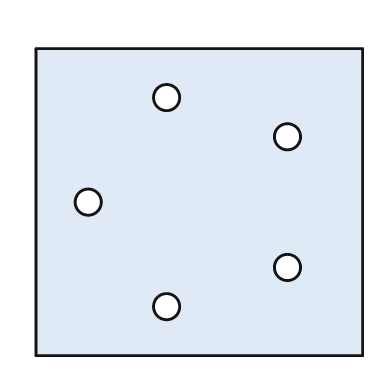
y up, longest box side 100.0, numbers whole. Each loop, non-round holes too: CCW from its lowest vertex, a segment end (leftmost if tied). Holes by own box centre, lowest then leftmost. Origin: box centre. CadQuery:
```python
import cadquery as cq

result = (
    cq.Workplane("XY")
    .moveTo(-50.0, -47.0)
    .lineTo(50.0, -47.0)
    .lineTo(50.0, 47.0)
    .lineTo(-50.0, 47.0)
    .close()
    .moveTo(-10.0, -32.0)
    .circle(4.0)
    .moveTo(27.0, -20.0)
    .circle(4.0)
    .moveTo(-34.0, 0.0)
    .circle(4.0)
    .moveTo(27.0, 20.0)
    .circle(4.0)
    .moveTo(-10.0, 32.0)
    .circle(4.0)
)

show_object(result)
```